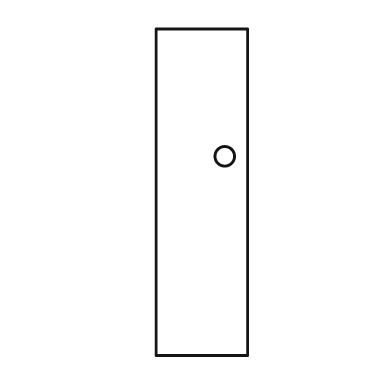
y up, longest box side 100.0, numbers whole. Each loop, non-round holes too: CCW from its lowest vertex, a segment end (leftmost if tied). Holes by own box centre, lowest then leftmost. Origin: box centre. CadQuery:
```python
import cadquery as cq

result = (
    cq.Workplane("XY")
    .moveTo(-14.0, -50.0)
    .lineTo(14.0, -50.0)
    .lineTo(14.0, 50.0)
    .lineTo(-14.0, 50.0)
    .close()
    .moveTo(7.0, 11.0)
    .circle(3.0)
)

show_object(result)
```